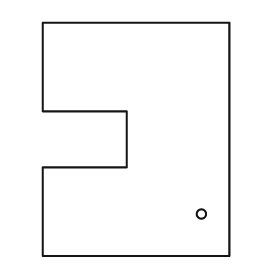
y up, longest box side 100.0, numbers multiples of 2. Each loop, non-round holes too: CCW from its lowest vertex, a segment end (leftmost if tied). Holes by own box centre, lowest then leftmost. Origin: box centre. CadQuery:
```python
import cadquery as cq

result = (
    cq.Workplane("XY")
    .moveTo(-40.0, -50.0)
    .lineTo(40.0, -50.0)
    .lineTo(40.0, 50.0)
    .lineTo(-40.0, 50.0)
    .lineTo(-40.0, 12.0)
    .lineTo(-4.0, 12.0)
    .lineTo(-4.0, -12.0)
    .lineTo(-40.0, -12.0)
    .close()
    .moveTo(28.0, -32.0)
    .circle(2.0)
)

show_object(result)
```